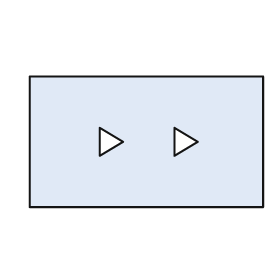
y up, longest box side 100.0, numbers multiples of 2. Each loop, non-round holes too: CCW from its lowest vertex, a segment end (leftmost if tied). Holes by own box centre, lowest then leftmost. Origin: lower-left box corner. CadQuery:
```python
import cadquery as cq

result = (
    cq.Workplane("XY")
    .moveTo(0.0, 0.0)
    .lineTo(100.0, 0.0)
    .lineTo(100.0, 56.0)
    .lineTo(0.0, 56.0)
    .close()
    .moveTo(30.0, 22.0)
    .lineTo(40.0, 28.0)
    .lineTo(30.0, 34.0)
    .close()
    .moveTo(62.0, 22.0)
    .lineTo(72.0, 28.0)
    .lineTo(62.0, 34.0)
    .close()
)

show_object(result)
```